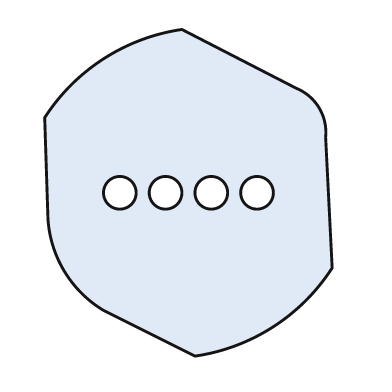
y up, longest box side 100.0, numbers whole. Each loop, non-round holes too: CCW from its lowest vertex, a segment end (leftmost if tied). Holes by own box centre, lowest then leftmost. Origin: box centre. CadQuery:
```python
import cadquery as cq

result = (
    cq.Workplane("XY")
    .moveTo(2.0, -50.0)
    .threePointArc((26.0, -41.0), (44.0, -23.0))
    .lineTo(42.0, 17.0)
    .threePointArc((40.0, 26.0), (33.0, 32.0))
    .lineTo(-2.0, 50.0)
    .threePointArc((-26.0, 41.0), (-44.0, 23.0))
    .lineTo(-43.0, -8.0)
    .threePointArc((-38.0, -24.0), (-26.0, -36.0))
    .close()
    .moveTo(-21.0, 0.0)
    .circle(5.0)
    .moveTo(-7.0, 0.0)
    .circle(5.0)
    .moveTo(7.0, 0.0)
    .circle(5.0)
    .moveTo(21.0, 0.0)
    .circle(5.0)
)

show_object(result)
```